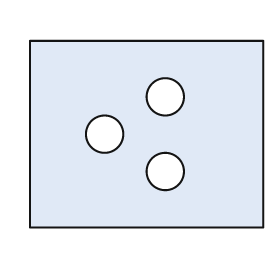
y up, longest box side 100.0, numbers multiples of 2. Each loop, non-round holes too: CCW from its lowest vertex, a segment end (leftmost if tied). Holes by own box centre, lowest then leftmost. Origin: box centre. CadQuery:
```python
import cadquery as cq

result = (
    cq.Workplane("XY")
    .moveTo(-50.0, -40.0)
    .lineTo(50.0, -40.0)
    .lineTo(50.0, 40.0)
    .lineTo(-50.0, 40.0)
    .close()
    .moveTo(8.0, -16.0)
    .circle(8.0)
    .moveTo(-18.0, 0.0)
    .circle(8.0)
    .moveTo(8.0, 16.0)
    .circle(8.0)
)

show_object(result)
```